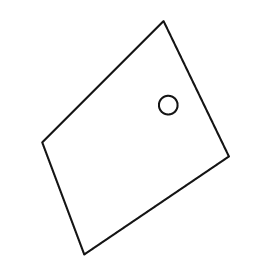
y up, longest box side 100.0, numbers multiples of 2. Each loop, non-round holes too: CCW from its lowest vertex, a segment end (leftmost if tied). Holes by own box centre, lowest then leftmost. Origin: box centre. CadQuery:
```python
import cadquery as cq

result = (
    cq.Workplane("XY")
    .moveTo(-22.0, -50.0)
    .lineTo(40.0, -8.0)
    .lineTo(12.0, 50.0)
    .lineTo(-40.0, -2.0)
    .close()
    .moveTo(14.0, 14.0)
    .circle(4.0)
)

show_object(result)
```